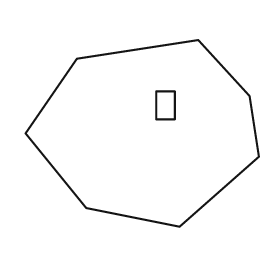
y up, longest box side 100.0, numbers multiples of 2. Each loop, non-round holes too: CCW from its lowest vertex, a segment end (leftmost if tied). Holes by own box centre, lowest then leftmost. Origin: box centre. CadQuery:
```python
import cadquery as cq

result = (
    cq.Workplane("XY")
    .moveTo(16.0, -40.0)
    .lineTo(50.0, -10.0)
    .lineTo(46.0, 16.0)
    .lineTo(24.0, 40.0)
    .lineTo(-28.0, 32.0)
    .lineTo(-50.0, 0.0)
    .lineTo(-24.0, -32.0)
    .close()
    .moveTo(6.0, 6.0)
    .lineTo(14.0, 6.0)
    .lineTo(14.0, 18.0)
    .lineTo(6.0, 18.0)
    .close()
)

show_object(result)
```